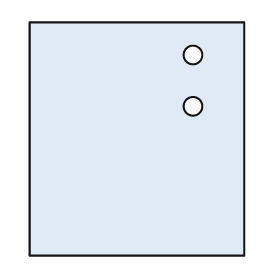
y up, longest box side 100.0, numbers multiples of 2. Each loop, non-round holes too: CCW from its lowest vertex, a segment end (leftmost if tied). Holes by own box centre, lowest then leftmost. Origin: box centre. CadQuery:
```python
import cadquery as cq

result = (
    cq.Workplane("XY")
    .moveTo(-46.0, -50.0)
    .lineTo(46.0, -50.0)
    .lineTo(46.0, 50.0)
    .lineTo(-46.0, 50.0)
    .close()
    .moveTo(24.0, 14.0)
    .circle(4.0)
    .moveTo(24.0, 36.0)
    .circle(4.0)
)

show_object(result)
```